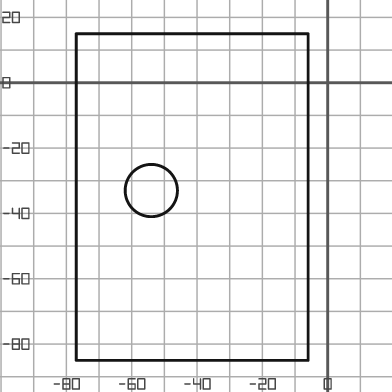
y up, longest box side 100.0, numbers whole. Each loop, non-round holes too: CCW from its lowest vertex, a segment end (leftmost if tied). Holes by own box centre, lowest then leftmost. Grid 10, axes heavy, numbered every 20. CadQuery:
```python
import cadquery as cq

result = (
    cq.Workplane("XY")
    .moveTo(-77.0, -85.0)
    .lineTo(-6.0, -85.0)
    .lineTo(-6.0, 15.0)
    .lineTo(-77.0, 15.0)
    .close()
    .moveTo(-54.0, -33.0)
    .circle(8.0)
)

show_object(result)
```